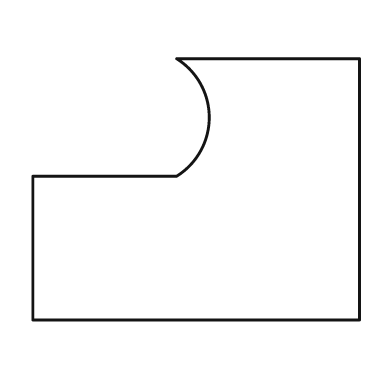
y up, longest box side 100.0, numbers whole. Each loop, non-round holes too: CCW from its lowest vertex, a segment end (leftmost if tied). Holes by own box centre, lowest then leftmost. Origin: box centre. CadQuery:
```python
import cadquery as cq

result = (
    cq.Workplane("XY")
    .moveTo(-50.0, -40.0)
    .lineTo(50.0, -40.0)
    .lineTo(50.0, 40.0)
    .lineTo(-6.0, 40.0)
    .threePointArc((4.0, 22.0), (-6.0, 4.0))
    .lineTo(-50.0, 4.0)
    .close()
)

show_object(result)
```